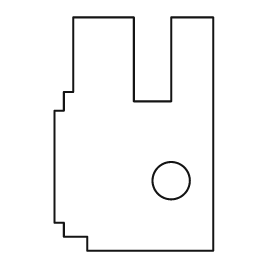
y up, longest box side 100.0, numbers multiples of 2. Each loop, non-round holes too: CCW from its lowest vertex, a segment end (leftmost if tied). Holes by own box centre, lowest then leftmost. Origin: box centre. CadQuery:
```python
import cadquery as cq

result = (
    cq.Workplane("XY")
    .moveTo(-20.0, -50.0)
    .lineTo(34.0, -50.0)
    .lineTo(34.0, 50.0)
    .lineTo(16.0, 50.0)
    .lineTo(16.0, 14.0)
    .lineTo(0.0, 14.0)
    .lineTo(0.0, 50.0)
    .lineTo(-26.0, 50.0)
    .lineTo(-26.0, 18.0)
    .lineTo(-30.0, 18.0)
    .lineTo(-30.0, 10.0)
    .lineTo(-34.0, 10.0)
    .lineTo(-34.0, -38.0)
    .lineTo(-30.0, -38.0)
    .lineTo(-30.0, -44.0)
    .lineTo(-20.0, -44.0)
    .close()
    .moveTo(16.0, -20.0)
    .circle(8.0)
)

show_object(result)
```